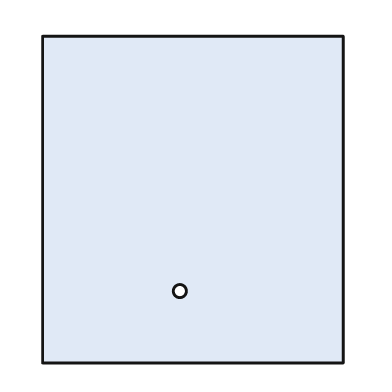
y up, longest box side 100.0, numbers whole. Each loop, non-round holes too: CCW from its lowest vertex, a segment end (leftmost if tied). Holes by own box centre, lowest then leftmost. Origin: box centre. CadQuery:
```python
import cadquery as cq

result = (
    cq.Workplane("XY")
    .moveTo(-46.0, -50.0)
    .lineTo(46.0, -50.0)
    .lineTo(46.0, 50.0)
    .lineTo(-46.0, 50.0)
    .close()
    .moveTo(-4.0, -28.0)
    .circle(2.0)
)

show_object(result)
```